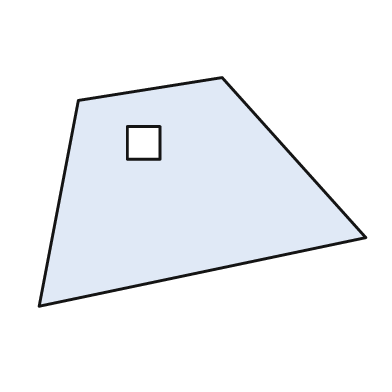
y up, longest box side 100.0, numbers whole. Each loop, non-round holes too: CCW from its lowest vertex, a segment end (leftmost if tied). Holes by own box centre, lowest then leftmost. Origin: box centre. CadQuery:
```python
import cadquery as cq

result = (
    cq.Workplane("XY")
    .moveTo(-50.0, -35.0)
    .lineTo(50.0, -14.0)
    .lineTo(6.0, 35.0)
    .lineTo(-38.0, 28.0)
    .close()
    .moveTo(-23.0, 10.0)
    .lineTo(-13.0, 10.0)
    .lineTo(-13.0, 20.0)
    .lineTo(-23.0, 20.0)
    .close()
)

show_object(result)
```